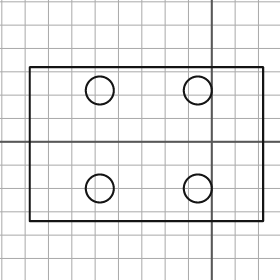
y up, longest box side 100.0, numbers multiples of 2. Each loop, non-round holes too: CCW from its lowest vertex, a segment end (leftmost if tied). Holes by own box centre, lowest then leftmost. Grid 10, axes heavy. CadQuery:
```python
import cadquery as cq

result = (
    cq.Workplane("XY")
    .moveTo(-78.0, -34.0)
    .lineTo(22.0, -34.0)
    .lineTo(22.0, 32.0)
    .lineTo(-78.0, 32.0)
    .close()
    .moveTo(-48.0, -20.0)
    .circle(6.0)
    .moveTo(-6.0, -20.0)
    .circle(6.0)
    .moveTo(-48.0, 22.0)
    .circle(6.0)
    .moveTo(-6.0, 22.0)
    .circle(6.0)
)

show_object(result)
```